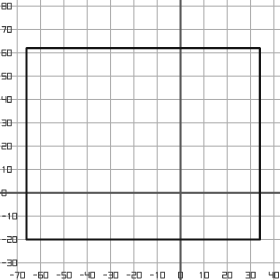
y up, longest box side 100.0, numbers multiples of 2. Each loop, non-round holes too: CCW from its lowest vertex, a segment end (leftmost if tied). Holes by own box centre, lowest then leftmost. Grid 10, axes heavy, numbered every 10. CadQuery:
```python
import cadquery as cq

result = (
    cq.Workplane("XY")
    .moveTo(-66.0, -20.0)
    .lineTo(34.0, -20.0)
    .lineTo(34.0, 62.0)
    .lineTo(-66.0, 62.0)
    .close()
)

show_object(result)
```